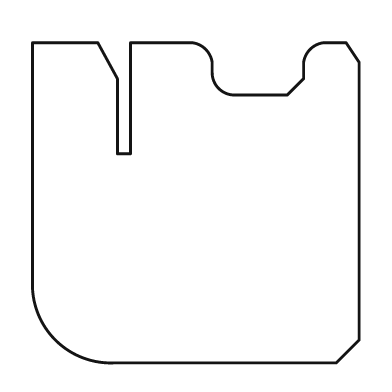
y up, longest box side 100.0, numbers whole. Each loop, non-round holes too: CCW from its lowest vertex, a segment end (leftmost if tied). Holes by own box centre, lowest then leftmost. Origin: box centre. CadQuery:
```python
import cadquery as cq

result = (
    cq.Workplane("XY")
    .moveTo(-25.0, -49.0)
    .lineTo(43.0, -49.0)
    .lineTo(50.0, -42.0)
    .lineTo(50.0, 43.0)
    .lineTo(46.0, 49.0)
    .lineTo(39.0, 49.0)
    .threePointArc((35.0, 47.0), (33.0, 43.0))
    .lineTo(33.0, 38.0)
    .lineTo(28.0, 33.0)
    .lineTo(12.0, 33.0)
    .threePointArc((7.0, 35.0), (5.0, 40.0))
    .lineTo(5.0, 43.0)
    .threePointArc((3.0, 47.0), (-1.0, 49.0))
    .lineTo(-20.0, 49.0)
    .lineTo(-20.0, 15.0)
    .lineTo(-24.0, 15.0)
    .lineTo(-24.0, 38.0)
    .lineTo(-30.0, 49.0)
    .lineTo(-50.0, 49.0)
    .lineTo(-50.0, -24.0)
    .threePointArc((-43.0, -42.0), (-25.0, -49.0))
    .close()
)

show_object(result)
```